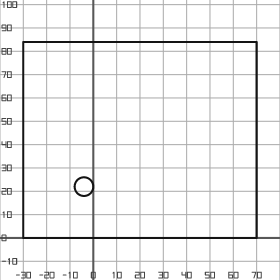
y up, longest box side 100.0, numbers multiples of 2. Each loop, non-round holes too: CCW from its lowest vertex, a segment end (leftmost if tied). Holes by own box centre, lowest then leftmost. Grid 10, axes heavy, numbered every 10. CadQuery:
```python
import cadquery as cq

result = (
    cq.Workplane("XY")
    .moveTo(-30.0, 0.0)
    .lineTo(70.0, 0.0)
    .lineTo(70.0, 84.0)
    .lineTo(-30.0, 84.0)
    .close()
    .moveTo(-4.0, 22.0)
    .circle(4.0)
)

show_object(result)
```